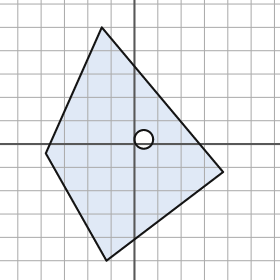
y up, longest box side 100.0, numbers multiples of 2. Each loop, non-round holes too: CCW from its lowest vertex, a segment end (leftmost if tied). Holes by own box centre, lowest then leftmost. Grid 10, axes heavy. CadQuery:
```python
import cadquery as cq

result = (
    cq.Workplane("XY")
    .moveTo(-12.0, -50.0)
    .lineTo(38.0, -12.0)
    .lineTo(-14.0, 50.0)
    .lineTo(-38.0, -4.0)
    .close()
    .moveTo(4.0, 2.0)
    .circle(4.0)
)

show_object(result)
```